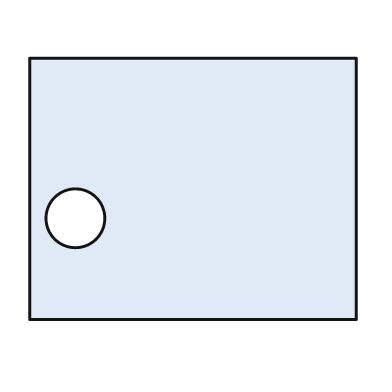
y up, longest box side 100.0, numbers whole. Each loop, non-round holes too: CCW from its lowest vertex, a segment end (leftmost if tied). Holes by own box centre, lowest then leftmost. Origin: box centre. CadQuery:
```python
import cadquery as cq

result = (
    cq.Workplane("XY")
    .moveTo(-50.0, -40.0)
    .lineTo(50.0, -40.0)
    .lineTo(50.0, 40.0)
    .lineTo(-50.0, 40.0)
    .close()
    .moveTo(-36.0, -9.0)
    .circle(9.0)
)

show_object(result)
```